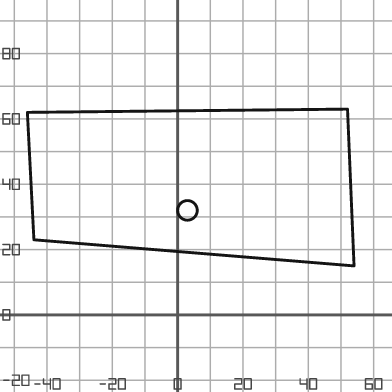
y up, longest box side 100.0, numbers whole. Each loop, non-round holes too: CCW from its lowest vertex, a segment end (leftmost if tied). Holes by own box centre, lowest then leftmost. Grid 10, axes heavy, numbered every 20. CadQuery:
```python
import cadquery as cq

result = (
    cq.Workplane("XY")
    .moveTo(54.0, 15.0)
    .lineTo(52.0, 63.0)
    .lineTo(-46.0, 62.0)
    .lineTo(-44.0, 23.0)
    .close()
    .moveTo(3.0, 32.0)
    .circle(3.0)
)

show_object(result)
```